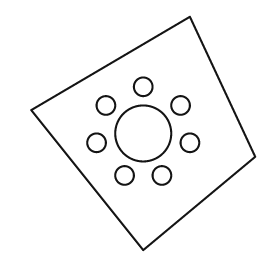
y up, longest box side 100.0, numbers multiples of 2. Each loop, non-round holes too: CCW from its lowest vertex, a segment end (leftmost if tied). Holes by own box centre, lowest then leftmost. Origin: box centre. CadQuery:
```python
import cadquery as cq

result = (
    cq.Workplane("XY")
    .moveTo(0.0, -50.0)
    .lineTo(48.0, -10.0)
    .lineTo(20.0, 50.0)
    .lineTo(-48.0, 10.0)
    .close()
    .moveTo(-8.0, -18.0)
    .circle(4.0)
    .moveTo(8.0, -18.0)
    .circle(4.0)
    .moveTo(-20.0, -4.0)
    .circle(4.0)
    .moveTo(20.0, -4.0)
    .circle(4.0)
    .moveTo(0.0, 0.0)
    .circle(12.0)
    .moveTo(-16.0, 12.0)
    .circle(4.0)
    .moveTo(16.0, 12.0)
    .circle(4.0)
    .moveTo(0.0, 20.0)
    .circle(4.0)
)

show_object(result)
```